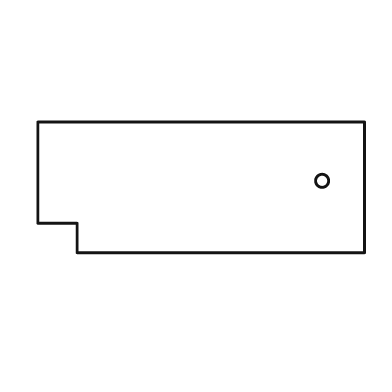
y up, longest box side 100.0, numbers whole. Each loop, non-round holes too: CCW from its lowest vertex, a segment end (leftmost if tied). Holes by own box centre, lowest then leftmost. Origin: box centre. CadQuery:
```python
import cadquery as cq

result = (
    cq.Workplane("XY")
    .moveTo(-38.0, -20.0)
    .lineTo(50.0, -20.0)
    .lineTo(50.0, 20.0)
    .lineTo(-50.0, 20.0)
    .lineTo(-50.0, -11.0)
    .lineTo(-38.0, -11.0)
    .close()
    .moveTo(37.0, 2.0)
    .circle(2.0)
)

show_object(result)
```